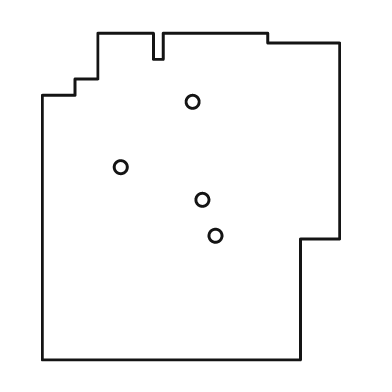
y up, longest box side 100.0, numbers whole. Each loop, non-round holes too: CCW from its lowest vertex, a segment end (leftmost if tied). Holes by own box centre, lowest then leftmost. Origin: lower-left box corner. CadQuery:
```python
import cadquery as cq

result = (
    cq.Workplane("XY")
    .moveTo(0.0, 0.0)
    .lineTo(79.0, 0.0)
    .lineTo(79.0, 37.0)
    .lineTo(91.0, 37.0)
    .lineTo(91.0, 97.0)
    .lineTo(69.0, 97.0)
    .lineTo(69.0, 100.0)
    .lineTo(37.0, 100.0)
    .lineTo(37.0, 92.0)
    .lineTo(34.0, 92.0)
    .lineTo(34.0, 100.0)
    .lineTo(17.0, 100.0)
    .lineTo(17.0, 86.0)
    .lineTo(10.0, 86.0)
    .lineTo(10.0, 81.0)
    .lineTo(0.0, 81.0)
    .close()
    .moveTo(53.0, 38.0)
    .circle(2.0)
    .moveTo(49.0, 49.0)
    .circle(2.0)
    .moveTo(24.0, 59.0)
    .circle(2.0)
    .moveTo(46.0, 79.0)
    .circle(2.0)
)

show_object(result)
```